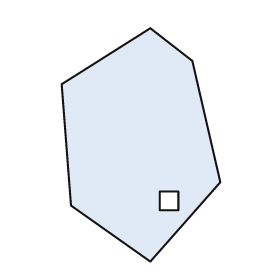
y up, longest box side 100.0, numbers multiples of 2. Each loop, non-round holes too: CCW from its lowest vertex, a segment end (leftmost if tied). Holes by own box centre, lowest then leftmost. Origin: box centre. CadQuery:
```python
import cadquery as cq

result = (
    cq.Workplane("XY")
    .moveTo(4.0, -50.0)
    .lineTo(34.0, -16.0)
    .lineTo(22.0, 36.0)
    .lineTo(4.0, 50.0)
    .lineTo(-34.0, 26.0)
    .lineTo(-30.0, -26.0)
    .close()
    .moveTo(8.0, -28.0)
    .lineTo(16.0, -28.0)
    .lineTo(16.0, -20.0)
    .lineTo(8.0, -20.0)
    .close()
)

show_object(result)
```